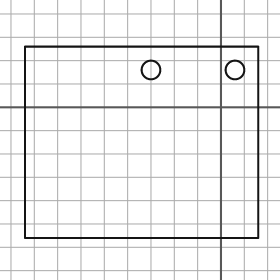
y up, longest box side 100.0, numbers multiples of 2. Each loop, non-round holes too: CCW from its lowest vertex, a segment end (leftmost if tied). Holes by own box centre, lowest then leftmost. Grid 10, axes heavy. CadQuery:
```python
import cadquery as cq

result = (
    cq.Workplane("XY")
    .moveTo(-84.0, -56.0)
    .lineTo(16.0, -56.0)
    .lineTo(16.0, 26.0)
    .lineTo(-84.0, 26.0)
    .close()
    .moveTo(-30.0, 16.0)
    .circle(4.0)
    .moveTo(6.0, 16.0)
    .circle(4.0)
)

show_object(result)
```